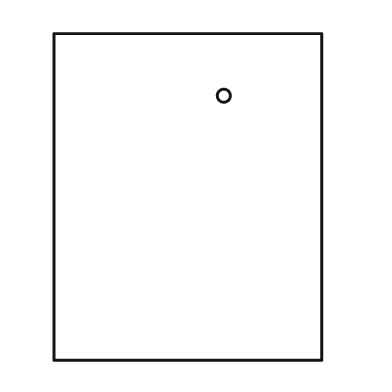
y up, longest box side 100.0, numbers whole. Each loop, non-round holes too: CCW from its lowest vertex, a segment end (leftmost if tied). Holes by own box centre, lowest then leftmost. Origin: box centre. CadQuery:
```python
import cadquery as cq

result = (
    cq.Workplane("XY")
    .moveTo(-41.0, -50.0)
    .lineTo(41.0, -50.0)
    .lineTo(41.0, 50.0)
    .lineTo(-41.0, 50.0)
    .close()
    .moveTo(11.0, 31.0)
    .circle(2.0)
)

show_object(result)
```